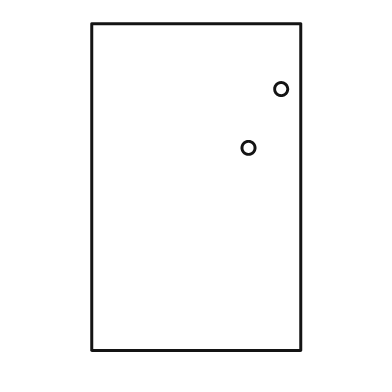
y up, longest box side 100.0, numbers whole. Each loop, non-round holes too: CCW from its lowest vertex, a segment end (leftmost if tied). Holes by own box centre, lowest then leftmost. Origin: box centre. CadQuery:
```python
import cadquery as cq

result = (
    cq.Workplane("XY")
    .moveTo(-32.0, -50.0)
    .lineTo(32.0, -50.0)
    .lineTo(32.0, 50.0)
    .lineTo(-32.0, 50.0)
    .close()
    .moveTo(16.0, 12.0)
    .circle(2.0)
    .moveTo(26.0, 30.0)
    .circle(2.0)
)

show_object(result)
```